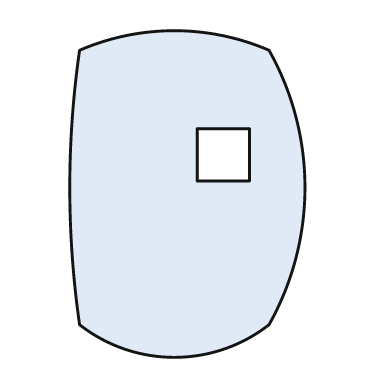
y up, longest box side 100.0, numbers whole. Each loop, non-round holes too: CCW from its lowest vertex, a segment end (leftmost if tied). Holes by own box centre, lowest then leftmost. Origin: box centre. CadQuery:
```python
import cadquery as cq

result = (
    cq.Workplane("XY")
    .moveTo(-33.0, -40.0)
    .threePointArc((-4.0, -50.0), (25.0, -40.0))
    .threePointArc((36.0, 2.0), (25.0, 44.0))
    .threePointArc((-4.0, 50.0), (-33.0, 44.0))
    .threePointArc((-36.0, 2.0), (-33.0, -40.0))
    .close()
    .moveTo(3.0, 4.0)
    .lineTo(19.0, 4.0)
    .lineTo(19.0, 20.0)
    .lineTo(3.0, 20.0)
    .close()
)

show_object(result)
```